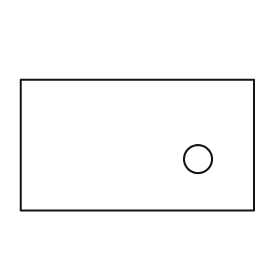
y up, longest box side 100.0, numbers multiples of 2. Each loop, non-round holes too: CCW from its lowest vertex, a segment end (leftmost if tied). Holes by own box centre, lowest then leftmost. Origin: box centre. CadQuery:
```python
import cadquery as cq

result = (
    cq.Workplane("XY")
    .moveTo(-50.0, -28.0)
    .lineTo(50.0, -28.0)
    .lineTo(50.0, 28.0)
    .lineTo(-50.0, 28.0)
    .close()
    .moveTo(26.0, -6.0)
    .circle(6.0)
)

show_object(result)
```